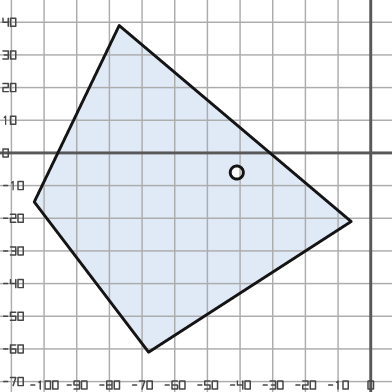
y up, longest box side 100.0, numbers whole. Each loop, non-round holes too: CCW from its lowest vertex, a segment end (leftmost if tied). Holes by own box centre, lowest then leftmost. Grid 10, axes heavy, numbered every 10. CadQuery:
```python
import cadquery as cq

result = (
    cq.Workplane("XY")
    .moveTo(-68.0, -61.0)
    .lineTo(-6.0, -21.0)
    .lineTo(-77.0, 39.0)
    .lineTo(-103.0, -15.0)
    .close()
    .moveTo(-41.0, -6.0)
    .circle(2.0)
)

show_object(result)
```